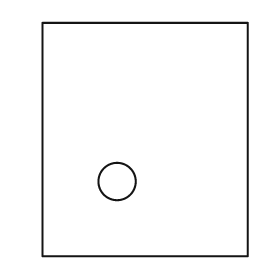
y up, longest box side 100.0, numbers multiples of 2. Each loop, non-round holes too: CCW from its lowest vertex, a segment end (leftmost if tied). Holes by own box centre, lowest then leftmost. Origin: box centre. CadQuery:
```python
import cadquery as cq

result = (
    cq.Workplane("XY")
    .moveTo(-44.0, -50.0)
    .lineTo(44.0, -50.0)
    .lineTo(44.0, 50.0)
    .lineTo(-44.0, 50.0)
    .close()
    .moveTo(-12.0, -18.0)
    .circle(8.0)
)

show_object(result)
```